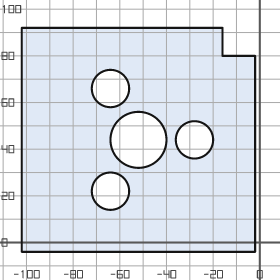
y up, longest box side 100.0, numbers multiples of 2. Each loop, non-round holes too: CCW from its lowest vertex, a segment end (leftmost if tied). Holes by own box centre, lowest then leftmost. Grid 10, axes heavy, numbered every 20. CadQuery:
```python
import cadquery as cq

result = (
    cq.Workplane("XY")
    .moveTo(-102.0, -4.0)
    .lineTo(-2.0, -4.0)
    .lineTo(-2.0, 80.0)
    .lineTo(-16.0, 80.0)
    .lineTo(-16.0, 92.0)
    .lineTo(-102.0, 92.0)
    .close()
    .moveTo(-64.0, 22.0)
    .circle(8.0)
    .moveTo(-52.0, 44.0)
    .circle(12.0)
    .moveTo(-28.0, 44.0)
    .circle(8.0)
    .moveTo(-64.0, 66.0)
    .circle(8.0)
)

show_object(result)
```